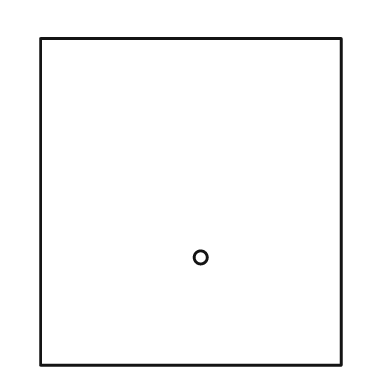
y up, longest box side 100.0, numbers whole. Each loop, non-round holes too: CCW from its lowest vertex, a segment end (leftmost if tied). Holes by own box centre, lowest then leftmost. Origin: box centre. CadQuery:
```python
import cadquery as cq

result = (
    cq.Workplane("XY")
    .moveTo(-46.0, -50.0)
    .lineTo(46.0, -50.0)
    .lineTo(46.0, 50.0)
    .lineTo(-46.0, 50.0)
    .close()
    .moveTo(3.0, -17.0)
    .circle(2.0)
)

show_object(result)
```